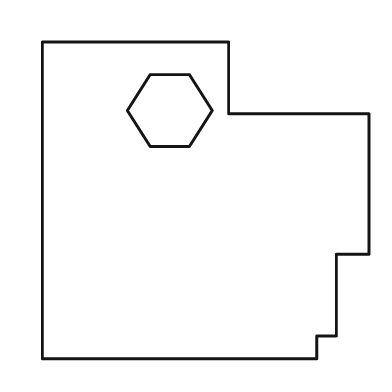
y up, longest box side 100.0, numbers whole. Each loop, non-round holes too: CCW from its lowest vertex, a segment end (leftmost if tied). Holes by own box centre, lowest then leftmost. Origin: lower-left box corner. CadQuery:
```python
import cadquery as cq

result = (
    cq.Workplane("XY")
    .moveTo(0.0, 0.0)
    .lineTo(84.0, 0.0)
    .lineTo(84.0, 7.0)
    .lineTo(90.0, 7.0)
    .lineTo(90.0, 32.0)
    .lineTo(100.0, 32.0)
    .lineTo(100.0, 75.0)
    .lineTo(57.0, 75.0)
    .lineTo(57.0, 97.0)
    .lineTo(0.0, 97.0)
    .close()
    .moveTo(33.0, 65.0)
    .lineTo(45.0, 65.0)
    .lineTo(52.0, 76.0)
    .lineTo(45.0, 87.0)
    .lineTo(33.0, 87.0)
    .lineTo(26.0, 76.0)
    .close()
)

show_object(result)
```